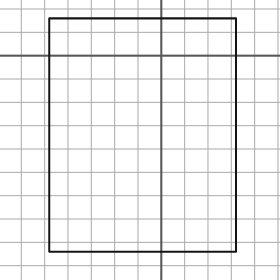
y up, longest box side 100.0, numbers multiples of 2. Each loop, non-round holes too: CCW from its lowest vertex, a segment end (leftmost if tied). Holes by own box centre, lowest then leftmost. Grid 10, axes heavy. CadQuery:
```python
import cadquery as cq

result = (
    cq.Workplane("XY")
    .moveTo(-48.0, -84.0)
    .lineTo(32.0, -84.0)
    .lineTo(32.0, 16.0)
    .lineTo(-48.0, 16.0)
    .close()
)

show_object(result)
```